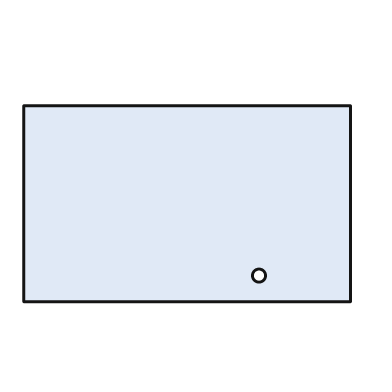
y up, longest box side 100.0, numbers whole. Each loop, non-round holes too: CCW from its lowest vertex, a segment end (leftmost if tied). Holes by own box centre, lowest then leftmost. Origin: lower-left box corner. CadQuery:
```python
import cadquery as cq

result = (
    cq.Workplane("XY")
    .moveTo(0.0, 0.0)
    .lineTo(100.0, 0.0)
    .lineTo(100.0, 60.0)
    .lineTo(0.0, 60.0)
    .close()
    .moveTo(72.0, 8.0)
    .circle(2.0)
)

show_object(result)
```